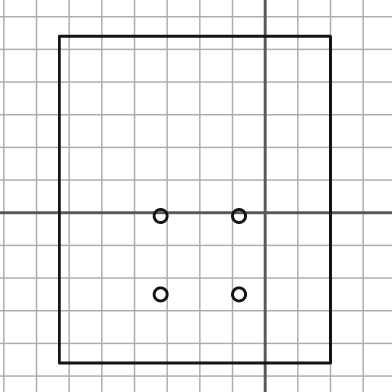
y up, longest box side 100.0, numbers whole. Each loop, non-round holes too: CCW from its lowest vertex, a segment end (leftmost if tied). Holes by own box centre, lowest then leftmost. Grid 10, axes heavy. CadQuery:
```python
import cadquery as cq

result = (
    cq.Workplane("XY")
    .moveTo(-63.0, -46.0)
    .lineTo(20.0, -46.0)
    .lineTo(20.0, 54.0)
    .lineTo(-63.0, 54.0)
    .close()
    .moveTo(-32.0, -25.0)
    .circle(2.0)
    .moveTo(-8.0, -25.0)
    .circle(2.0)
    .moveTo(-32.0, -1.0)
    .circle(2.0)
    .moveTo(-8.0, -1.0)
    .circle(2.0)
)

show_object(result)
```